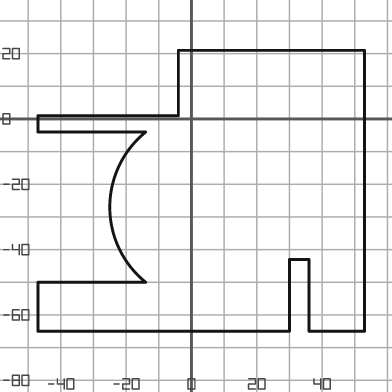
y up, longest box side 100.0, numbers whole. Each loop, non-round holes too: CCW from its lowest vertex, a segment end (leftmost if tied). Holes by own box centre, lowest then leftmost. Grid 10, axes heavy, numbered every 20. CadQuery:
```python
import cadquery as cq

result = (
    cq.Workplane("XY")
    .moveTo(-47.0, -65.0)
    .lineTo(30.0, -65.0)
    .lineTo(30.0, -43.0)
    .lineTo(36.0, -43.0)
    .lineTo(36.0, -65.0)
    .lineTo(53.0, -65.0)
    .lineTo(53.0, 21.0)
    .lineTo(-4.0, 21.0)
    .lineTo(-4.0, 1.0)
    .lineTo(-47.0, 1.0)
    .lineTo(-47.0, -4.0)
    .lineTo(-14.0, -4.0)
    .threePointArc((-25.0, -27.0), (-14.0, -50.0))
    .lineTo(-47.0, -50.0)
    .close()
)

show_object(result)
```